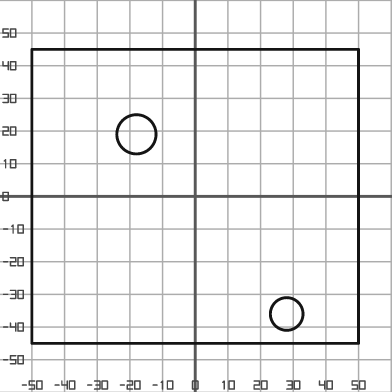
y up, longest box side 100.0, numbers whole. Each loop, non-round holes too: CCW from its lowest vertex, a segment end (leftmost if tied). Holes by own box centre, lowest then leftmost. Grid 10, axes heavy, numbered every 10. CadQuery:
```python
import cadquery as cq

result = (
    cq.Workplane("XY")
    .moveTo(-50.0, -45.0)
    .lineTo(50.0, -45.0)
    .lineTo(50.0, 45.0)
    .lineTo(-50.0, 45.0)
    .close()
    .moveTo(28.0, -36.0)
    .circle(5.0)
    .moveTo(-18.0, 19.0)
    .circle(6.0)
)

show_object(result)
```